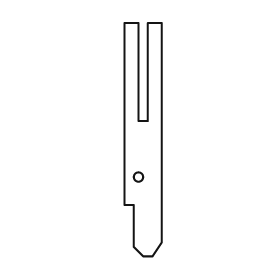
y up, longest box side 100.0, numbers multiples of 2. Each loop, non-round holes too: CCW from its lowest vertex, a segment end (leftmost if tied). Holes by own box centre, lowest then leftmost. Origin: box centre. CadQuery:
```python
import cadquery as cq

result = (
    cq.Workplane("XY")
    .moveTo(0.0, -50.0)
    .lineTo(4.0, -50.0)
    .lineTo(8.0, -44.0)
    .lineTo(8.0, 50.0)
    .lineTo(2.0, 50.0)
    .lineTo(2.0, 8.0)
    .lineTo(-2.0, 8.0)
    .lineTo(-2.0, 50.0)
    .lineTo(-8.0, 50.0)
    .lineTo(-8.0, -28.0)
    .lineTo(-4.0, -28.0)
    .lineTo(-4.0, -46.0)
    .close()
    .moveTo(-2.0, -16.0)
    .circle(2.0)
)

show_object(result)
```